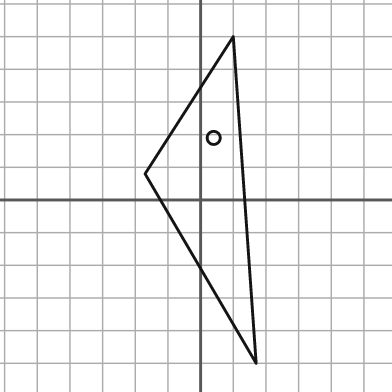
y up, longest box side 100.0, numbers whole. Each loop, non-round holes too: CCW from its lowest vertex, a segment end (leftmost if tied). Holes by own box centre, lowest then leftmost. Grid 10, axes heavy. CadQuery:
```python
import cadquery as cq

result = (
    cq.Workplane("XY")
    .moveTo(17.0, -50.0)
    .lineTo(10.0, 50.0)
    .lineTo(-17.0, 8.0)
    .close()
    .moveTo(4.0, 19.0)
    .circle(2.0)
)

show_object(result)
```